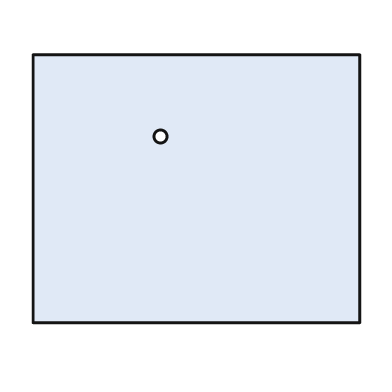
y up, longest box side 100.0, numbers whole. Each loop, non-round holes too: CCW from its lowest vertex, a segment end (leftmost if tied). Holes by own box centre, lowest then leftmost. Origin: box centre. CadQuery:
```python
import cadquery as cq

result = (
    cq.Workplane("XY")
    .moveTo(-50.0, -41.0)
    .lineTo(50.0, -41.0)
    .lineTo(50.0, 41.0)
    .lineTo(-50.0, 41.0)
    .close()
    .moveTo(-11.0, 16.0)
    .circle(2.0)
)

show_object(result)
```